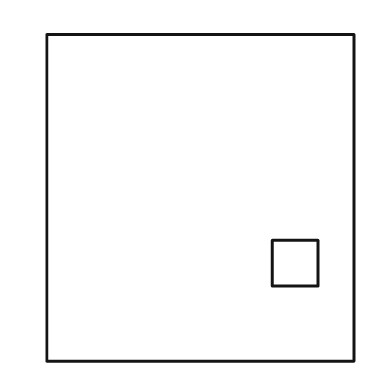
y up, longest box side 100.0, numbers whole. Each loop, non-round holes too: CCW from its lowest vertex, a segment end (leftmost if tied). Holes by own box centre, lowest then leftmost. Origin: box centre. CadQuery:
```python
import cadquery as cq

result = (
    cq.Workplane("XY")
    .moveTo(-47.0, -50.0)
    .lineTo(47.0, -50.0)
    .lineTo(47.0, 50.0)
    .lineTo(-47.0, 50.0)
    .close()
    .moveTo(22.0, -27.0)
    .lineTo(36.0, -27.0)
    .lineTo(36.0, -13.0)
    .lineTo(22.0, -13.0)
    .close()
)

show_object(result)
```